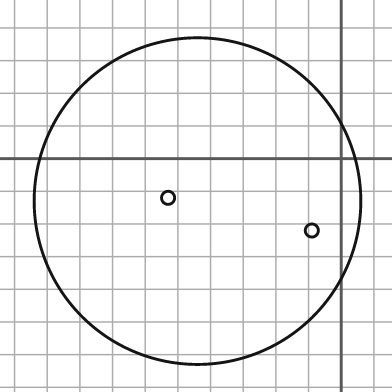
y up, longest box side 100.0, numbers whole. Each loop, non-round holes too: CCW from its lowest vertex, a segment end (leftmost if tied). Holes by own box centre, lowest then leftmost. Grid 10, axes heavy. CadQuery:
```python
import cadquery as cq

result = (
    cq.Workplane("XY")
    .moveTo(-44.0, -13.0)
    .circle(50.0)
    .moveTo(-9.0, -22.0)
    .circle(2.0)
    .moveTo(-53.0, -12.0)
    .circle(2.0)
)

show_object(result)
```